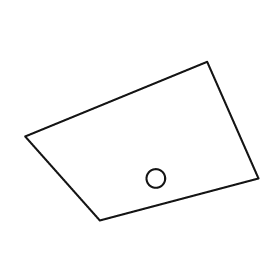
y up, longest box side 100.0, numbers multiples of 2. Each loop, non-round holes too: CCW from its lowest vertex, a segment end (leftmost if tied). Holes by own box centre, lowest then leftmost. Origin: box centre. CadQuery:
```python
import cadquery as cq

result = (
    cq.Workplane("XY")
    .moveTo(-18.0, -34.0)
    .lineTo(50.0, -16.0)
    .lineTo(28.0, 34.0)
    .lineTo(-50.0, 2.0)
    .close()
    .moveTo(6.0, -16.0)
    .circle(4.0)
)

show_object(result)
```